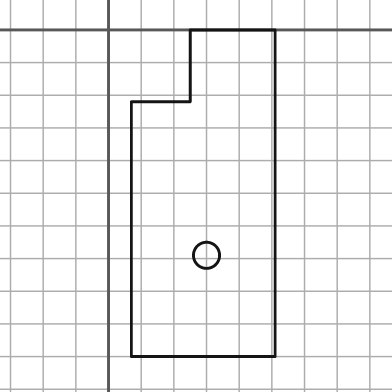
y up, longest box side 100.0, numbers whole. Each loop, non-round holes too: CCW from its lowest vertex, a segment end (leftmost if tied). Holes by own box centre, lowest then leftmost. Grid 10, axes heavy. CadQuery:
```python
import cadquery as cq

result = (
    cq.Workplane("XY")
    .moveTo(7.0, -100.0)
    .lineTo(51.0, -100.0)
    .lineTo(51.0, 0.0)
    .lineTo(25.0, 0.0)
    .lineTo(25.0, -22.0)
    .lineTo(7.0, -22.0)
    .close()
    .moveTo(30.0, -69.0)
    .circle(4.0)
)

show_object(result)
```